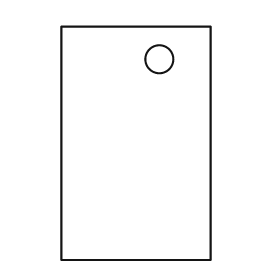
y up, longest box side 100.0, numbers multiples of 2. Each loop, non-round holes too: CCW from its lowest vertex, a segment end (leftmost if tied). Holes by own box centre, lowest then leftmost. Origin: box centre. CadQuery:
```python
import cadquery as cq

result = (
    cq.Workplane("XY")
    .moveTo(-32.0, -50.0)
    .lineTo(32.0, -50.0)
    .lineTo(32.0, 50.0)
    .lineTo(-32.0, 50.0)
    .close()
    .moveTo(10.0, 36.0)
    .circle(6.0)
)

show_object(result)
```